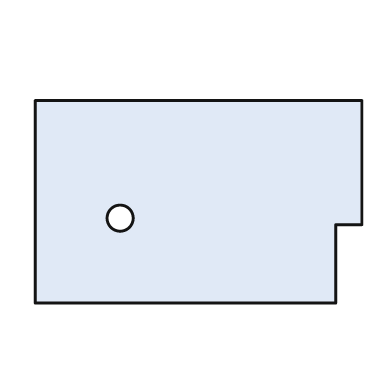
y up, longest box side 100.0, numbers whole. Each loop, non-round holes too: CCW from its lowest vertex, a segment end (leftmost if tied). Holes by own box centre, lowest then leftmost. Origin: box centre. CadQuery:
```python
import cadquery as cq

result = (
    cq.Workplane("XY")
    .moveTo(-50.0, -31.0)
    .lineTo(42.0, -31.0)
    .lineTo(42.0, -7.0)
    .lineTo(50.0, -7.0)
    .lineTo(50.0, 31.0)
    .lineTo(-50.0, 31.0)
    .close()
    .moveTo(-24.0, -5.0)
    .circle(4.0)
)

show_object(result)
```